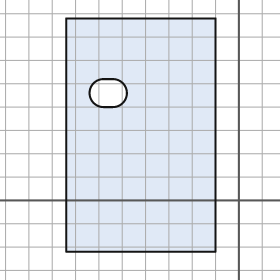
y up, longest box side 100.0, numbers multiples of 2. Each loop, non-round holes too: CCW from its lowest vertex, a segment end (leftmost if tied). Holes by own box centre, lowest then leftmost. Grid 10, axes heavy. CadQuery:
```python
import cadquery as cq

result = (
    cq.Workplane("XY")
    .moveTo(-74.0, -22.0)
    .lineTo(-10.0, -22.0)
    .lineTo(-10.0, 78.0)
    .lineTo(-74.0, 78.0)
    .close()
    .moveTo(-58.0, 40.0)
    .lineTo(-54.0, 40.0)
    .threePointArc((-48.0, 46.0), (-54.0, 52.0))
    .lineTo(-58.0, 52.0)
    .threePointArc((-64.0, 46.0), (-58.0, 40.0))
    .close()
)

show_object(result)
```